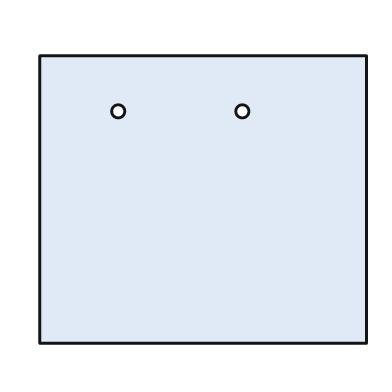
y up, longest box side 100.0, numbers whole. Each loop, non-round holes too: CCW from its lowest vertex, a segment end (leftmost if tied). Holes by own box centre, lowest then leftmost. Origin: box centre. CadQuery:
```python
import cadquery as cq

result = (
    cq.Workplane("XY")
    .moveTo(-50.0, -44.0)
    .lineTo(50.0, -44.0)
    .lineTo(50.0, 44.0)
    .lineTo(-50.0, 44.0)
    .close()
    .moveTo(-26.0, 27.0)
    .circle(2.0)
    .moveTo(12.0, 27.0)
    .circle(2.0)
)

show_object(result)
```